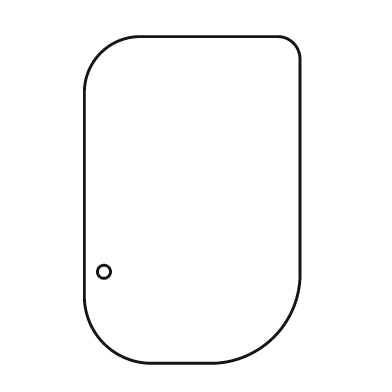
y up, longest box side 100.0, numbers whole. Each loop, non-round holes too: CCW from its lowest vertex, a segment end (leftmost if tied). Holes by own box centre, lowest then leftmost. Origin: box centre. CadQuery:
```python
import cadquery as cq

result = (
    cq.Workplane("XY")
    .moveTo(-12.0, -50.0)
    .lineTo(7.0, -50.0)
    .threePointArc((25.0, -42.0), (33.0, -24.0))
    .lineTo(33.0, 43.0)
    .threePointArc((31.0, 48.0), (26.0, 50.0))
    .lineTo(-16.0, 50.0)
    .threePointArc((-28.0, 45.0), (-33.0, 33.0))
    .lineTo(-33.0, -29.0)
    .threePointArc((-27.0, -44.0), (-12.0, -50.0))
    .close()
    .moveTo(-27.0, -22.0)
    .circle(2.0)
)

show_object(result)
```